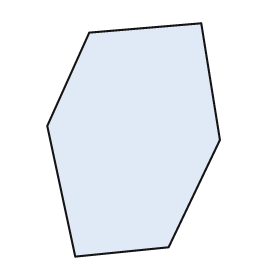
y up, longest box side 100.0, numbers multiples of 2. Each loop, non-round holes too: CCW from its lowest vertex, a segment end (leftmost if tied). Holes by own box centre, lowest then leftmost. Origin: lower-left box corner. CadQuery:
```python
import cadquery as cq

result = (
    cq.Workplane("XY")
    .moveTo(12.0, 0.0)
    .lineTo(52.0, 4.0)
    .lineTo(74.0, 50.0)
    .lineTo(66.0, 100.0)
    .lineTo(18.0, 96.0)
    .lineTo(0.0, 56.0)
    .close()
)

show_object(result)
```